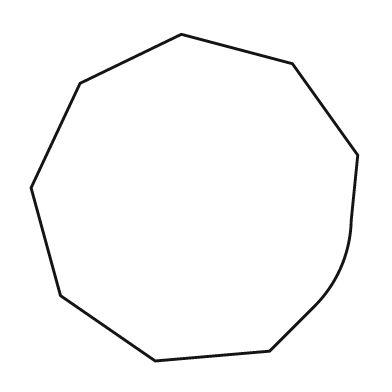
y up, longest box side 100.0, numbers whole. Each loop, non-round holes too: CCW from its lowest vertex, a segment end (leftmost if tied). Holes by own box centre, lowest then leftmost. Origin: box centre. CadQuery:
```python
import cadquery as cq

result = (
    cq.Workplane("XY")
    .moveTo(-12.0, -50.0)
    .lineTo(23.0, -47.0)
    .lineTo(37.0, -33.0)
    .threePointArc((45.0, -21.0), (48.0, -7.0))
    .lineTo(50.0, 13.0)
    .lineTo(30.0, 41.0)
    .lineTo(-4.0, 50.0)
    .lineTo(-35.0, 35.0)
    .lineTo(-50.0, 3.0)
    .lineTo(-41.0, -30.0)
    .close()
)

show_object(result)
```